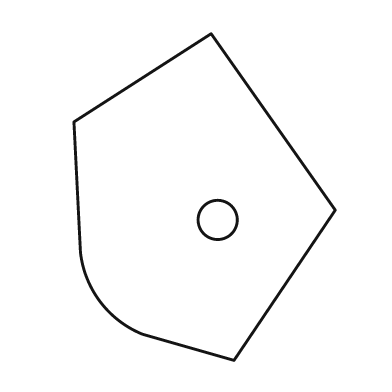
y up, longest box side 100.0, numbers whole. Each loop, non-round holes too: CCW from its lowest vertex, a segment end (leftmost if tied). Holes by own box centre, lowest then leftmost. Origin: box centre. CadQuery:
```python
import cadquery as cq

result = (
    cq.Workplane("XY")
    .moveTo(9.0, -50.0)
    .lineTo(40.0, -4.0)
    .lineTo(2.0, 50.0)
    .lineTo(-40.0, 23.0)
    .lineTo(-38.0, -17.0)
    .threePointArc((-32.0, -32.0), (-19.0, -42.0))
    .close()
    .moveTo(4.0, -7.0)
    .circle(6.0)
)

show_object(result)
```